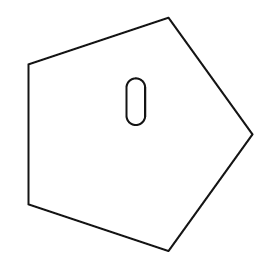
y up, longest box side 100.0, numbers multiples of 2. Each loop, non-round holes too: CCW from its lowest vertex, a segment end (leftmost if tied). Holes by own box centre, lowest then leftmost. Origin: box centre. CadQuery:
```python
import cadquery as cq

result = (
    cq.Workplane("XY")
    .moveTo(12.0, -50.0)
    .lineTo(48.0, 0.0)
    .lineTo(12.0, 50.0)
    .lineTo(-48.0, 30.0)
    .lineTo(-48.0, -30.0)
    .close()
    .moveTo(-6.0, 8.0)
    .threePointArc((-2.0, 4.0), (2.0, 8.0))
    .lineTo(2.0, 20.0)
    .threePointArc((-2.0, 24.0), (-6.0, 20.0))
    .close()
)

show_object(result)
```